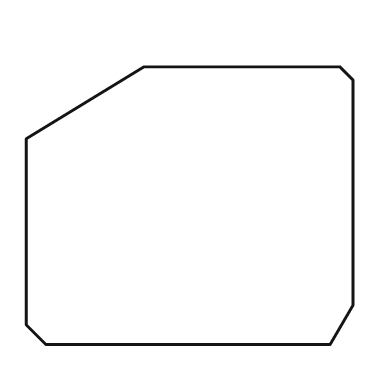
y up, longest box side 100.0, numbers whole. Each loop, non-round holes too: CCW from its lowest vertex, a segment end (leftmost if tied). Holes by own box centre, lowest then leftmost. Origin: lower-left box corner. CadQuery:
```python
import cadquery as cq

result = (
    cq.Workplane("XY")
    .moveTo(6.0, 0.0)
    .lineTo(93.0, 0.0)
    .lineTo(100.0, 12.0)
    .lineTo(100.0, 81.0)
    .lineTo(96.0, 85.0)
    .lineTo(36.0, 85.0)
    .lineTo(0.0, 63.0)
    .lineTo(0.0, 6.0)
    .close()
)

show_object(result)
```